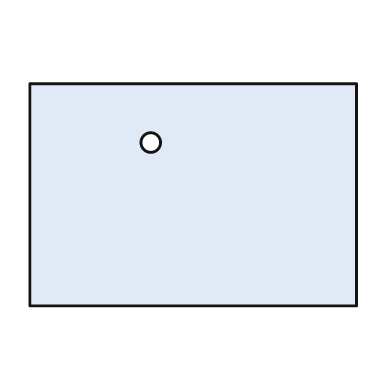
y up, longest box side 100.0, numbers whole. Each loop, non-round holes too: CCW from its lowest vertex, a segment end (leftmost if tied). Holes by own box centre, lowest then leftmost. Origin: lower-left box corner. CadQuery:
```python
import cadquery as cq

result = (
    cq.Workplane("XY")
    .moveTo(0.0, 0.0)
    .lineTo(100.0, 0.0)
    .lineTo(100.0, 68.0)
    .lineTo(0.0, 68.0)
    .close()
    .moveTo(37.0, 50.0)
    .circle(3.0)
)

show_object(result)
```